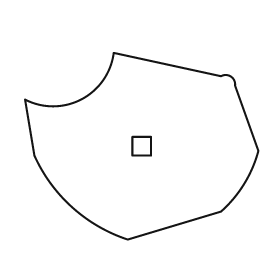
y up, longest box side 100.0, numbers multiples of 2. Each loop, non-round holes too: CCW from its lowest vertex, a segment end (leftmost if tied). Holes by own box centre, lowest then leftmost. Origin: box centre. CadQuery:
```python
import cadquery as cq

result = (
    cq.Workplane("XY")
    .moveTo(-6.0, -40.0)
    .lineTo(34.0, -28.0)
    .threePointArc((44.0, -16.0), (50.0, -2.0))
    .lineTo(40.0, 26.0)
    .threePointArc((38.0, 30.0), (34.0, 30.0))
    .lineTo(-12.0, 40.0)
    .threePointArc((-26.0, 20.0), (-50.0, 20.0))
    .lineTo(-46.0, -4.0)
    .threePointArc((-30.0, -26.0), (-6.0, -40.0))
    .close()
    .moveTo(-4.0, -4.0)
    .lineTo(4.0, -4.0)
    .lineTo(4.0, 4.0)
    .lineTo(-4.0, 4.0)
    .close()
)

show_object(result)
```